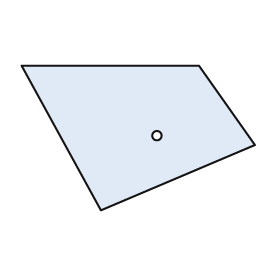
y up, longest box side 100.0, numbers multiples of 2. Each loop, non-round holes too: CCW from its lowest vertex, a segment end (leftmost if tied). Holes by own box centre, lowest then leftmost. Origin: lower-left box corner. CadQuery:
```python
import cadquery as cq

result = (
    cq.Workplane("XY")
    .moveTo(34.0, 0.0)
    .lineTo(100.0, 28.0)
    .lineTo(76.0, 62.0)
    .lineTo(0.0, 62.0)
    .close()
    .moveTo(58.0, 32.0)
    .circle(2.0)
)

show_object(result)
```